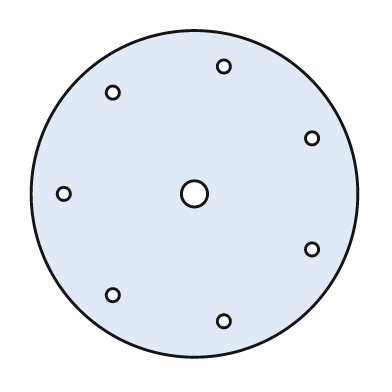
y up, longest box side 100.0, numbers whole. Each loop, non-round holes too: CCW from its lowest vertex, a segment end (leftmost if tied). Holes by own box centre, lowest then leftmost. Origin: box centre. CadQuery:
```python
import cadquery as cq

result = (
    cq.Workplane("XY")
    .moveTo(0.0, 0.0)
    .circle(50.0)
    .moveTo(9.0, -39.0)
    .circle(2.0)
    .moveTo(-25.0, -31.0)
    .circle(2.0)
    .moveTo(36.0, -17.0)
    .circle(2.0)
    .moveTo(-40.0, 0.0)
    .circle(2.0)
    .moveTo(0.0, 0.0)
    .circle(4.0)
    .moveTo(36.0, 17.0)
    .circle(2.0)
    .moveTo(-25.0, 31.0)
    .circle(2.0)
    .moveTo(9.0, 39.0)
    .circle(2.0)
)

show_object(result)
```